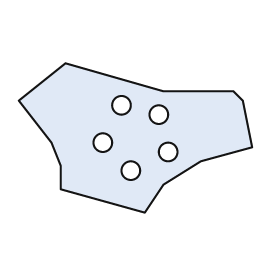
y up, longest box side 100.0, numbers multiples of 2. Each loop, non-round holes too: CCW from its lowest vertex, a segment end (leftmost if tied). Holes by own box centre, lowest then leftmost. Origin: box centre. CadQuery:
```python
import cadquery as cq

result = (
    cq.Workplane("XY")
    .moveTo(4.0, -32.0)
    .lineTo(12.0, -20.0)
    .lineTo(28.0, -10.0)
    .lineTo(50.0, -4.0)
    .lineTo(46.0, 16.0)
    .lineTo(42.0, 20.0)
    .lineTo(12.0, 20.0)
    .lineTo(-30.0, 32.0)
    .lineTo(-50.0, 16.0)
    .lineTo(-36.0, -2.0)
    .lineTo(-32.0, -12.0)
    .lineTo(-32.0, -22.0)
    .close()
    .moveTo(-2.0, -14.0)
    .circle(4.0)
    .moveTo(14.0, -6.0)
    .circle(4.0)
    .moveTo(-14.0, -2.0)
    .circle(4.0)
    .moveTo(10.0, 10.0)
    .circle(4.0)
    .moveTo(-6.0, 14.0)
    .circle(4.0)
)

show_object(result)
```